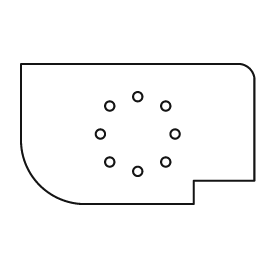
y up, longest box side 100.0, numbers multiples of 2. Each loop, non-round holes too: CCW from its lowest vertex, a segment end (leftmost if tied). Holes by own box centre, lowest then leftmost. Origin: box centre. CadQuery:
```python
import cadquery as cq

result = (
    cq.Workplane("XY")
    .moveTo(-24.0, -30.0)
    .lineTo(24.0, -30.0)
    .lineTo(24.0, -20.0)
    .lineTo(50.0, -20.0)
    .lineTo(50.0, 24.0)
    .threePointArc((48.0, 28.0), (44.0, 30.0))
    .lineTo(-50.0, 30.0)
    .lineTo(-50.0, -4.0)
    .threePointArc((-42.0, -22.0), (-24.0, -30.0))
    .close()
    .moveTo(0.0, -16.0)
    .circle(2.0)
    .moveTo(-12.0, -12.0)
    .circle(2.0)
    .moveTo(12.0, -12.0)
    .circle(2.0)
    .moveTo(-16.0, 0.0)
    .circle(2.0)
    .moveTo(16.0, 0.0)
    .circle(2.0)
    .moveTo(-12.0, 12.0)
    .circle(2.0)
    .moveTo(12.0, 12.0)
    .circle(2.0)
    .moveTo(0.0, 16.0)
    .circle(2.0)
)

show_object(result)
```